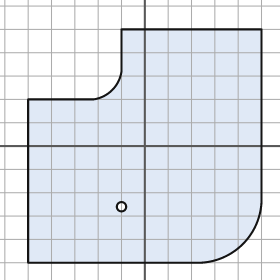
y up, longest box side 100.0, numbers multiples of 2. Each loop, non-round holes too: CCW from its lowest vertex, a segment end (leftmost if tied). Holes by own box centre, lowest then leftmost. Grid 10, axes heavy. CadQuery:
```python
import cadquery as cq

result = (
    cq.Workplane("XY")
    .moveTo(-50.0, -50.0)
    .lineTo(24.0, -50.0)
    .threePointArc((42.0, -42.0), (50.0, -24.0))
    .lineTo(50.0, 50.0)
    .lineTo(-10.0, 50.0)
    .lineTo(-10.0, 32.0)
    .threePointArc((-14.0, 24.0), (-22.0, 20.0))
    .lineTo(-50.0, 20.0)
    .close()
    .moveTo(-10.0, -26.0)
    .circle(2.0)
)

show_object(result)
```